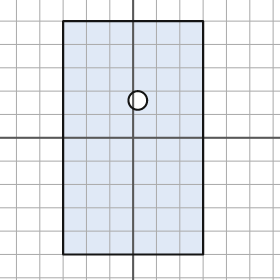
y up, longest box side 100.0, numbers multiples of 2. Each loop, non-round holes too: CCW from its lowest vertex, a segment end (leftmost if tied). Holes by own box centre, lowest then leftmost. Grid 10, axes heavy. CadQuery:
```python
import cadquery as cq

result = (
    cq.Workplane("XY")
    .moveTo(-30.0, -50.0)
    .lineTo(30.0, -50.0)
    .lineTo(30.0, 50.0)
    .lineTo(-30.0, 50.0)
    .close()
    .moveTo(2.0, 16.0)
    .circle(4.0)
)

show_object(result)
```